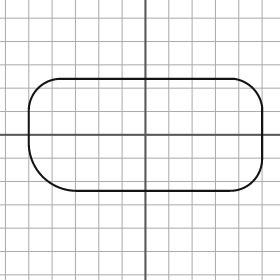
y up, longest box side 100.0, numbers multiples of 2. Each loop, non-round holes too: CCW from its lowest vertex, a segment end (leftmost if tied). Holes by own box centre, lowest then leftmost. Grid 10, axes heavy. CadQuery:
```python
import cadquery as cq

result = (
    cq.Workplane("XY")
    .moveTo(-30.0, -24.0)
    .lineTo(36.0, -24.0)
    .threePointArc((46.0, -20.0), (50.0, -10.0))
    .lineTo(50.0, 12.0)
    .threePointArc((46.0, 20.0), (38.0, 24.0))
    .lineTo(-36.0, 24.0)
    .threePointArc((-46.0, 20.0), (-50.0, 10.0))
    .lineTo(-50.0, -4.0)
    .threePointArc((-44.0, -18.0), (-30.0, -24.0))
    .close()
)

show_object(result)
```